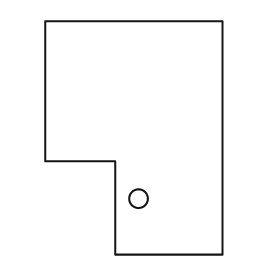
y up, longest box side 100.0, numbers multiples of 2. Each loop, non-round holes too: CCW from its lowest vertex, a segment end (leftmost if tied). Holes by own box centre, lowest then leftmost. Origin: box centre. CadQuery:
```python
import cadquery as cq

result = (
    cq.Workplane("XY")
    .moveTo(-8.0, -50.0)
    .lineTo(38.0, -50.0)
    .lineTo(38.0, 50.0)
    .lineTo(-38.0, 50.0)
    .lineTo(-38.0, -10.0)
    .lineTo(-8.0, -10.0)
    .close()
    .moveTo(2.0, -26.0)
    .circle(4.0)
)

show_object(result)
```